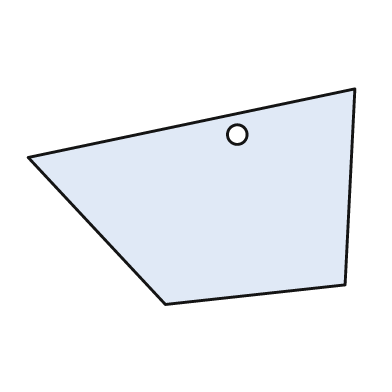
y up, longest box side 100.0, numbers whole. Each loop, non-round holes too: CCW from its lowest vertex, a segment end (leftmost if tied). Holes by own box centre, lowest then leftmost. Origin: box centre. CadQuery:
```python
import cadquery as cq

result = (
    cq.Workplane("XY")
    .moveTo(-8.0, -33.0)
    .lineTo(47.0, -27.0)
    .lineTo(50.0, 33.0)
    .lineTo(-50.0, 12.0)
    .close()
    .moveTo(14.0, 19.0)
    .circle(3.0)
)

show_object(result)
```